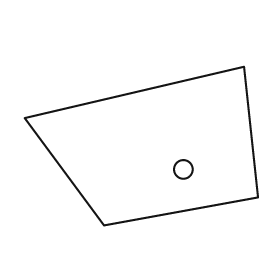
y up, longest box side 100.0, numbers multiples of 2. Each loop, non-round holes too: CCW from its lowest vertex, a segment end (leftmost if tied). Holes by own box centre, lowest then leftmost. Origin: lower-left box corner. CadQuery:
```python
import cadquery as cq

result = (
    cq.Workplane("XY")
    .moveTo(34.0, 0.0)
    .lineTo(100.0, 12.0)
    .lineTo(94.0, 68.0)
    .lineTo(0.0, 46.0)
    .close()
    .moveTo(68.0, 24.0)
    .circle(4.0)
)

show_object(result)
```